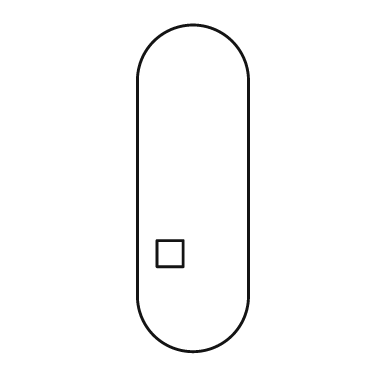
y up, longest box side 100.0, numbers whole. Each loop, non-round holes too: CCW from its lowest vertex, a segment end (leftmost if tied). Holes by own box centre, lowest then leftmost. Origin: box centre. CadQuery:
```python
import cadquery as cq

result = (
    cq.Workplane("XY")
    .moveTo(-17.0, -33.0)
    .threePointArc((0.0, -50.0), (17.0, -33.0))
    .lineTo(17.0, 33.0)
    .threePointArc((0.0, 50.0), (-17.0, 33.0))
    .close()
    .moveTo(-11.0, -24.0)
    .lineTo(-3.0, -24.0)
    .lineTo(-3.0, -16.0)
    .lineTo(-11.0, -16.0)
    .close()
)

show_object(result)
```